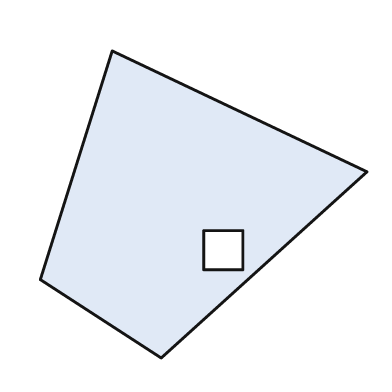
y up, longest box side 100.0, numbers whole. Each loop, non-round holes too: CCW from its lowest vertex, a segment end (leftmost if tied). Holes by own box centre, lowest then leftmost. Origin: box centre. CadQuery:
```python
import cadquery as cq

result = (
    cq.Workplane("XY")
    .moveTo(-13.0, -47.0)
    .lineTo(50.0, 10.0)
    .lineTo(-28.0, 47.0)
    .lineTo(-50.0, -23.0)
    .close()
    .moveTo(0.0, -20.0)
    .lineTo(12.0, -20.0)
    .lineTo(12.0, -8.0)
    .lineTo(0.0, -8.0)
    .close()
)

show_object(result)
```